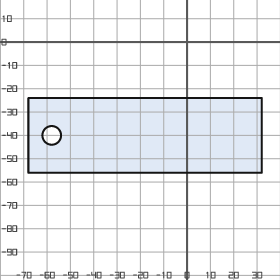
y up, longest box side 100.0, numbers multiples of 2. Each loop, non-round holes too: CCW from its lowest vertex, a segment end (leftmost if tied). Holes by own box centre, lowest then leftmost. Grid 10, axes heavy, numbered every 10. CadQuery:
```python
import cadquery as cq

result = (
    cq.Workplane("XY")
    .moveTo(-68.0, -56.0)
    .lineTo(32.0, -56.0)
    .lineTo(32.0, -24.0)
    .lineTo(-68.0, -24.0)
    .close()
    .moveTo(-58.0, -40.0)
    .circle(4.0)
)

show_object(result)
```